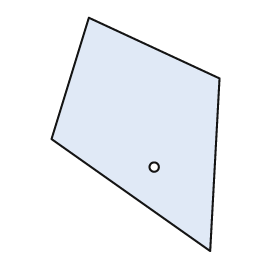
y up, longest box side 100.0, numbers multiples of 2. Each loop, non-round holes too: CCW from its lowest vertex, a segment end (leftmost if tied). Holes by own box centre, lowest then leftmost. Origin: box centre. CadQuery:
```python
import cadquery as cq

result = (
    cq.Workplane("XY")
    .moveTo(32.0, -50.0)
    .lineTo(36.0, 24.0)
    .lineTo(-20.0, 50.0)
    .lineTo(-36.0, -2.0)
    .close()
    .moveTo(8.0, -14.0)
    .circle(2.0)
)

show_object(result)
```